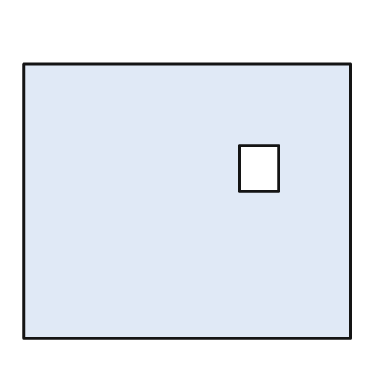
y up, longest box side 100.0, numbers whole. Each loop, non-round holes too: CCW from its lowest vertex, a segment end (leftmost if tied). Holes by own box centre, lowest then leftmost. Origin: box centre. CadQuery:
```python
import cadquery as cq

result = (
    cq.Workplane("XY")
    .moveTo(-50.0, -42.0)
    .lineTo(50.0, -42.0)
    .lineTo(50.0, 42.0)
    .lineTo(-50.0, 42.0)
    .close()
    .moveTo(16.0, 3.0)
    .lineTo(28.0, 3.0)
    .lineTo(28.0, 17.0)
    .lineTo(16.0, 17.0)
    .close()
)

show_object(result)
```